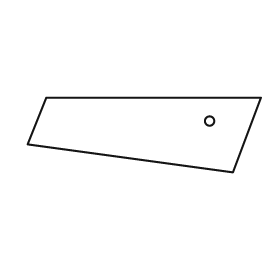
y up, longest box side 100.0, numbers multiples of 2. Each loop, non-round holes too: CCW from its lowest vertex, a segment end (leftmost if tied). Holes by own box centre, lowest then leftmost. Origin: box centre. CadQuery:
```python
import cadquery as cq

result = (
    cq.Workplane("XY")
    .moveTo(38.0, -16.0)
    .lineTo(50.0, 16.0)
    .lineTo(-42.0, 16.0)
    .lineTo(-50.0, -4.0)
    .close()
    .moveTo(28.0, 6.0)
    .circle(2.0)
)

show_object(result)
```